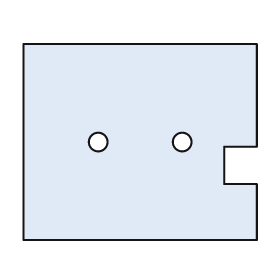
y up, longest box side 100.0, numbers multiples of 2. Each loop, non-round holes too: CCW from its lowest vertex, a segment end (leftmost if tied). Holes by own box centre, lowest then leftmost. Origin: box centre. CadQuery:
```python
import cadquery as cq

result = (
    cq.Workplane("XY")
    .moveTo(-50.0, -42.0)
    .lineTo(50.0, -42.0)
    .lineTo(50.0, -18.0)
    .lineTo(36.0, -18.0)
    .lineTo(36.0, -2.0)
    .lineTo(50.0, -2.0)
    .lineTo(50.0, 42.0)
    .lineTo(-50.0, 42.0)
    .close()
    .moveTo(-18.0, 0.0)
    .circle(4.0)
    .moveTo(18.0, 0.0)
    .circle(4.0)
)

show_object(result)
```